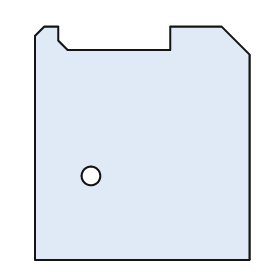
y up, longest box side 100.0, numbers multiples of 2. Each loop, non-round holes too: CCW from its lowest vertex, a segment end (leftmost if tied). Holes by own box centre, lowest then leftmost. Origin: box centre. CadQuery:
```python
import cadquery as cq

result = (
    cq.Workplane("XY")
    .moveTo(-46.0, -50.0)
    .lineTo(46.0, -50.0)
    .lineTo(46.0, 38.0)
    .lineTo(34.0, 50.0)
    .lineTo(12.0, 50.0)
    .lineTo(12.0, 40.0)
    .lineTo(-32.0, 40.0)
    .lineTo(-36.0, 44.0)
    .lineTo(-36.0, 50.0)
    .lineTo(-42.0, 50.0)
    .lineTo(-46.0, 46.0)
    .close()
    .moveTo(-22.0, -14.0)
    .circle(4.0)
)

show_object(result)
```